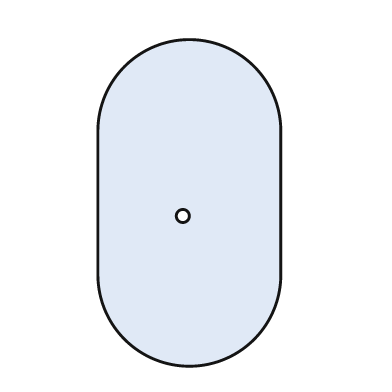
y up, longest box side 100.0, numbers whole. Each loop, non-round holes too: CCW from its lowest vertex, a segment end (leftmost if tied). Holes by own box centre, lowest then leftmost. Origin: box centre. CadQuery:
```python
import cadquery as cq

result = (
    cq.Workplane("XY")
    .moveTo(-28.0, -22.0)
    .threePointArc((0.0, -50.0), (28.0, -22.0))
    .lineTo(28.0, 22.0)
    .threePointArc((0.0, 50.0), (-28.0, 22.0))
    .close()
    .moveTo(-2.0, -4.0)
    .circle(2.0)
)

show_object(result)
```